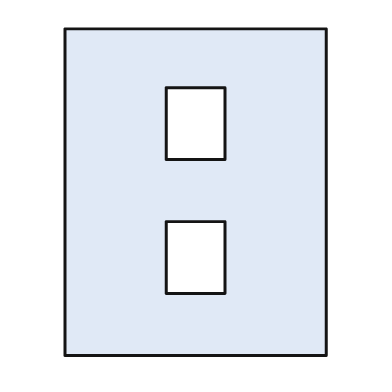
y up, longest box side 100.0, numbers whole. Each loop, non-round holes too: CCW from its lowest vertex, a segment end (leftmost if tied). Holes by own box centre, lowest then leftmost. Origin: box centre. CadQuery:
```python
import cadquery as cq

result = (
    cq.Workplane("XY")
    .moveTo(-40.0, -50.0)
    .lineTo(40.0, -50.0)
    .lineTo(40.0, 50.0)
    .lineTo(-40.0, 50.0)
    .close()
    .moveTo(-9.0, -31.0)
    .lineTo(9.0, -31.0)
    .lineTo(9.0, -9.0)
    .lineTo(-9.0, -9.0)
    .close()
    .moveTo(-9.0, 10.0)
    .lineTo(9.0, 10.0)
    .lineTo(9.0, 32.0)
    .lineTo(-9.0, 32.0)
    .close()
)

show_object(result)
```